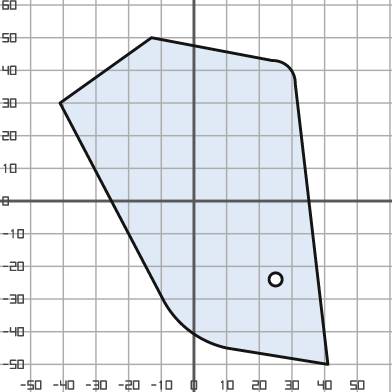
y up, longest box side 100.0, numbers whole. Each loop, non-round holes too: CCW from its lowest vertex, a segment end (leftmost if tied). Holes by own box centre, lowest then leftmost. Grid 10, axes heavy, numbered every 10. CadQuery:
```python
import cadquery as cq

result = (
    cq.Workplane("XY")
    .moveTo(41.0, -50.0)
    .lineTo(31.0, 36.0)
    .threePointArc((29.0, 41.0), (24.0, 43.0))
    .lineTo(-13.0, 50.0)
    .lineTo(-41.0, 30.0)
    .lineTo(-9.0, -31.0)
    .threePointArc((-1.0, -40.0), (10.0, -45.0))
    .close()
    .moveTo(25.0, -24.0)
    .circle(2.0)
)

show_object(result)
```